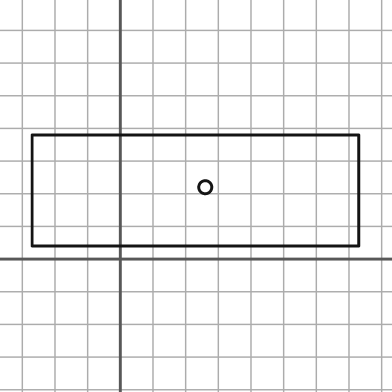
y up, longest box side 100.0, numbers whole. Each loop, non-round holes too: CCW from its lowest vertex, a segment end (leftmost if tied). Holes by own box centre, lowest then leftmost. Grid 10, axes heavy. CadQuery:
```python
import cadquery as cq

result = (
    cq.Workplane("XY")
    .moveTo(-27.0, 4.0)
    .lineTo(73.0, 4.0)
    .lineTo(73.0, 38.0)
    .lineTo(-27.0, 38.0)
    .close()
    .moveTo(26.0, 22.0)
    .circle(2.0)
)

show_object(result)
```